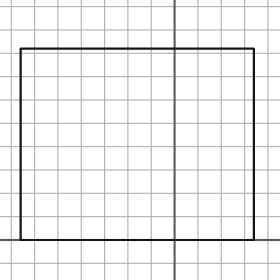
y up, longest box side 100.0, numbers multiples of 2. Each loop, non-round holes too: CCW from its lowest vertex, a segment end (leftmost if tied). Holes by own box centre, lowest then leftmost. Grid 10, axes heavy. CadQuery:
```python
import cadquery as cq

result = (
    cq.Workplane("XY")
    .moveTo(-66.0, 0.0)
    .lineTo(34.0, 0.0)
    .lineTo(34.0, 82.0)
    .lineTo(-66.0, 82.0)
    .close()
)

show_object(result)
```